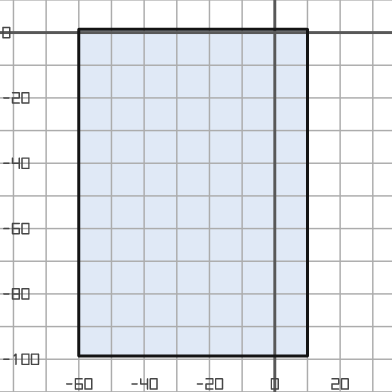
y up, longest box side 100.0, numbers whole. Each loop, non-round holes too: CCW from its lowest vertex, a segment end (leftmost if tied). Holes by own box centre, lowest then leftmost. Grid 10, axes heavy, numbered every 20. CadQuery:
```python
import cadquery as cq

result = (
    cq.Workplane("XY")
    .moveTo(-60.0, -99.0)
    .lineTo(10.0, -99.0)
    .lineTo(10.0, 1.0)
    .lineTo(-60.0, 1.0)
    .close()
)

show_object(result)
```